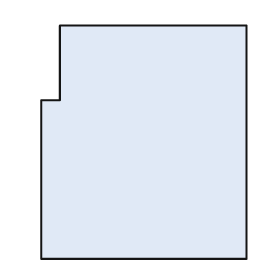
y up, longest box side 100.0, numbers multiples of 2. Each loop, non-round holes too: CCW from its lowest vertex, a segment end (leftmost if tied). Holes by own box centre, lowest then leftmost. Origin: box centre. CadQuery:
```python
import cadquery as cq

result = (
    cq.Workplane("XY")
    .moveTo(-44.0, -50.0)
    .lineTo(44.0, -50.0)
    .lineTo(44.0, 50.0)
    .lineTo(-36.0, 50.0)
    .lineTo(-36.0, 18.0)
    .lineTo(-44.0, 18.0)
    .close()
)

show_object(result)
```